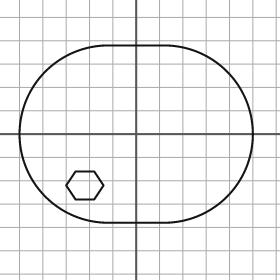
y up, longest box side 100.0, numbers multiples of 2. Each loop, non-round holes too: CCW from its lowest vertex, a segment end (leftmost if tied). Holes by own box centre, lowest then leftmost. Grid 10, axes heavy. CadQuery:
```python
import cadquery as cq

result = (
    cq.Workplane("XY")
    .moveTo(-12.0, -38.0)
    .lineTo(12.0, -38.0)
    .threePointArc((50.0, 0.0), (12.0, 38.0))
    .lineTo(-12.0, 38.0)
    .threePointArc((-50.0, 0.0), (-12.0, -38.0))
    .close()
    .moveTo(-26.0, -28.0)
    .lineTo(-18.0, -28.0)
    .lineTo(-14.0, -22.0)
    .lineTo(-18.0, -16.0)
    .lineTo(-26.0, -16.0)
    .lineTo(-30.0, -22.0)
    .close()
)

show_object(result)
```